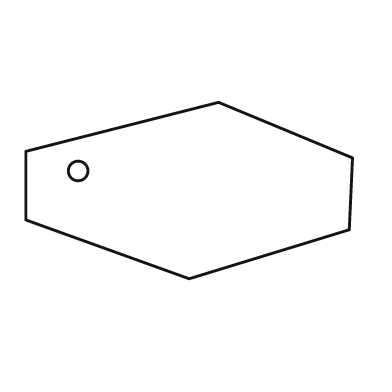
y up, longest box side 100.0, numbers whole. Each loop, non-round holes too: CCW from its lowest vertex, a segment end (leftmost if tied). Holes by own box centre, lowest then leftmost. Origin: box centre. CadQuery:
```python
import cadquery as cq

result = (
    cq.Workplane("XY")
    .moveTo(0.0, -27.0)
    .lineTo(49.0, -12.0)
    .lineTo(50.0, 10.0)
    .lineTo(9.0, 27.0)
    .lineTo(-50.0, 12.0)
    .lineTo(-50.0, -9.0)
    .close()
    .moveTo(-34.0, 6.0)
    .circle(3.0)
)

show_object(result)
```